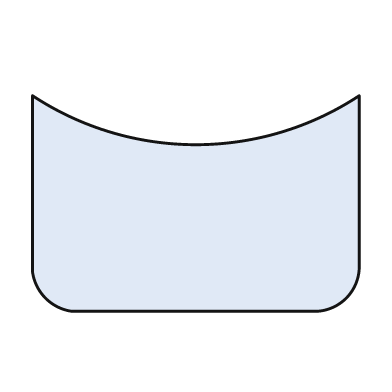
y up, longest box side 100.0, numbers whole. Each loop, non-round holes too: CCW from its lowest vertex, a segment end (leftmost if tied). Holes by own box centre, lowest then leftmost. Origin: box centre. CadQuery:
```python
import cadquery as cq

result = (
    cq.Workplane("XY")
    .moveTo(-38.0, -33.0)
    .lineTo(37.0, -33.0)
    .threePointArc((46.0, -29.0), (50.0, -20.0))
    .lineTo(50.0, 33.0)
    .threePointArc((0.0, 18.0), (-50.0, 33.0))
    .lineTo(-50.0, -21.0)
    .threePointArc((-46.0, -29.0), (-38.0, -33.0))
    .close()
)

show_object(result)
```